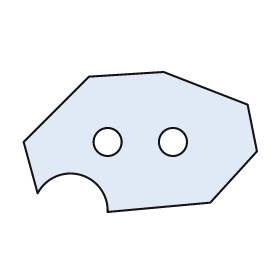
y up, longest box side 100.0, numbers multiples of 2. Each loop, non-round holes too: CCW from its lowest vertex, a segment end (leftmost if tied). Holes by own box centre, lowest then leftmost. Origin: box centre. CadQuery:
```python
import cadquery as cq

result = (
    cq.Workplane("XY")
    .moveTo(-14.0, -30.0)
    .lineTo(30.0, -26.0)
    .lineTo(50.0, -4.0)
    .lineTo(46.0, 16.0)
    .lineTo(10.0, 30.0)
    .lineTo(-22.0, 28.0)
    .lineTo(-50.0, 0.0)
    .lineTo(-44.0, -22.0)
    .threePointArc((-26.0, -14.0), (-14.0, -30.0))
    .close()
    .moveTo(-14.0, 0.0)
    .circle(6.0)
    .moveTo(14.0, 0.0)
    .circle(6.0)
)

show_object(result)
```